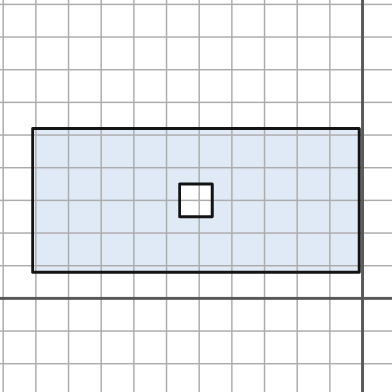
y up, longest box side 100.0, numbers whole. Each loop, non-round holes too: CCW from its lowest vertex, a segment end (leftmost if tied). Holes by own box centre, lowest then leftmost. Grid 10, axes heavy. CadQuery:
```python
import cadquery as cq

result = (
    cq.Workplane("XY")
    .moveTo(-101.0, 8.0)
    .lineTo(-1.0, 8.0)
    .lineTo(-1.0, 52.0)
    .lineTo(-101.0, 52.0)
    .close()
    .moveTo(-56.0, 25.0)
    .lineTo(-46.0, 25.0)
    .lineTo(-46.0, 35.0)
    .lineTo(-56.0, 35.0)
    .close()
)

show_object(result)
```